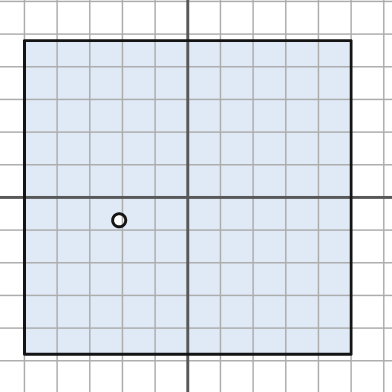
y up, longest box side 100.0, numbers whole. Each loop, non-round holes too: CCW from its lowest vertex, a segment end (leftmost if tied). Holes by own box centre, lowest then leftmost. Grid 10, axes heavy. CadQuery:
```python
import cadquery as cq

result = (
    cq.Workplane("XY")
    .moveTo(-50.0, -48.0)
    .lineTo(50.0, -48.0)
    .lineTo(50.0, 48.0)
    .lineTo(-50.0, 48.0)
    .close()
    .moveTo(-21.0, -7.0)
    .circle(2.0)
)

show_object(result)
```